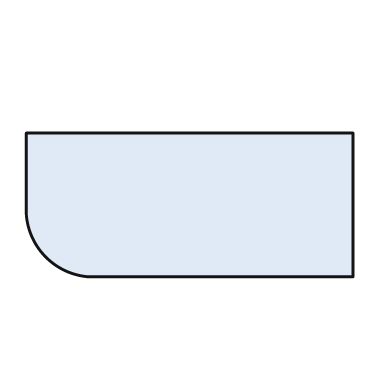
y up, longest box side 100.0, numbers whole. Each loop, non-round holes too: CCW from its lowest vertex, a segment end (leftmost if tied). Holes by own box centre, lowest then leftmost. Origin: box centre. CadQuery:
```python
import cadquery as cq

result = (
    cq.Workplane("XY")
    .moveTo(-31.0, -22.0)
    .lineTo(50.0, -22.0)
    .lineTo(50.0, 22.0)
    .lineTo(-50.0, 22.0)
    .lineTo(-50.0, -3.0)
    .threePointArc((-44.0, -16.0), (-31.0, -22.0))
    .close()
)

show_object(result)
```